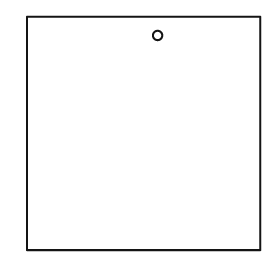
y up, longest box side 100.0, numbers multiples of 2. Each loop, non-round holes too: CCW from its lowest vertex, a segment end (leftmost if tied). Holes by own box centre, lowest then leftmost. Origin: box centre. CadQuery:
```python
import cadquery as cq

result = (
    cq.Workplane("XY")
    .moveTo(-50.0, -50.0)
    .lineTo(50.0, -50.0)
    .lineTo(50.0, 50.0)
    .lineTo(-50.0, 50.0)
    .close()
    .moveTo(6.0, 42.0)
    .circle(2.0)
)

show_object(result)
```